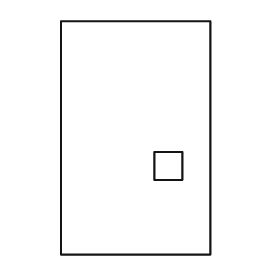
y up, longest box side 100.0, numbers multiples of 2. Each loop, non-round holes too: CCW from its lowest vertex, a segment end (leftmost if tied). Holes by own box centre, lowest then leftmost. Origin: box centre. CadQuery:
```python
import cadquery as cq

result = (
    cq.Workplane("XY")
    .moveTo(-32.0, -50.0)
    .lineTo(32.0, -50.0)
    .lineTo(32.0, 50.0)
    .lineTo(-32.0, 50.0)
    .close()
    .moveTo(8.0, -18.0)
    .lineTo(20.0, -18.0)
    .lineTo(20.0, -6.0)
    .lineTo(8.0, -6.0)
    .close()
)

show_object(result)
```